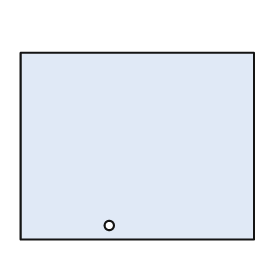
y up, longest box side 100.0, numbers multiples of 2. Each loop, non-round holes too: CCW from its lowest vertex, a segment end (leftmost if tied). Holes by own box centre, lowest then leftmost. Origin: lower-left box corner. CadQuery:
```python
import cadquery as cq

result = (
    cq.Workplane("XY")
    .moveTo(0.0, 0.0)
    .lineTo(100.0, 0.0)
    .lineTo(100.0, 80.0)
    .lineTo(0.0, 80.0)
    .close()
    .moveTo(38.0, 6.0)
    .circle(2.0)
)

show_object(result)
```